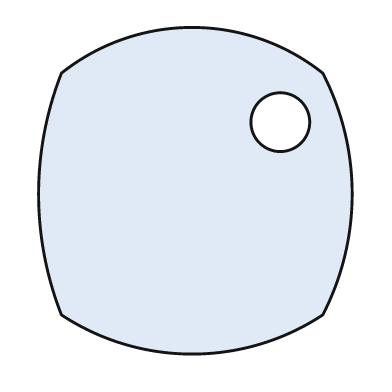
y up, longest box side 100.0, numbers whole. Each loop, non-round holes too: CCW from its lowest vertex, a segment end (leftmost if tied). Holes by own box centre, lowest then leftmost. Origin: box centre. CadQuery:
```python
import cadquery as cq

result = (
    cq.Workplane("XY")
    .moveTo(-41.0, -38.0)
    .threePointArc((-1.0, -50.0), (39.0, -38.0))
    .threePointArc((48.0, -1.0), (39.0, 36.0))
    .threePointArc((-1.0, 50.0), (-41.0, 36.0))
    .threePointArc((-48.0, -1.0), (-41.0, -38.0))
    .close()
    .moveTo(26.0, 21.0)
    .circle(9.0)
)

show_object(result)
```